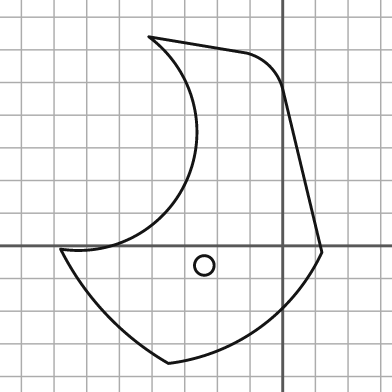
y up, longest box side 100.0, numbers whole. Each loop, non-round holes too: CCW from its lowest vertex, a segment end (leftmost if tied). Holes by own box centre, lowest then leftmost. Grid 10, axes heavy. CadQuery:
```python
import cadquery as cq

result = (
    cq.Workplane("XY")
    .moveTo(-35.0, -36.0)
    .threePointArc((-7.0, -25.0), (12.0, -2.0))
    .lineTo(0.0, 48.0)
    .threePointArc((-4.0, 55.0), (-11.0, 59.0))
    .lineTo(-41.0, 64.0)
    .threePointArc((-29.0, 21.0), (-68.0, -1.0))
    .threePointArc((-54.0, -21.0), (-35.0, -36.0))
    .close()
    .moveTo(-24.0, -6.0)
    .circle(3.0)
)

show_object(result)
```